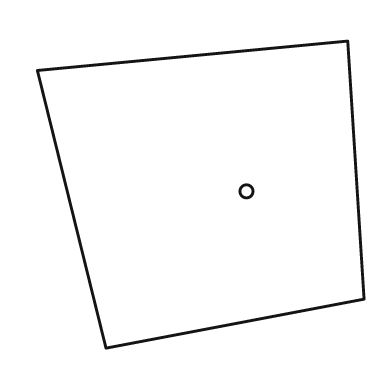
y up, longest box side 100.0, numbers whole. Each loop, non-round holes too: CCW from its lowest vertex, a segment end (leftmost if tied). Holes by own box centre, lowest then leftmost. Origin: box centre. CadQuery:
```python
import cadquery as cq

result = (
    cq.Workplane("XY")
    .moveTo(-29.0, -47.0)
    .lineTo(50.0, -32.0)
    .lineTo(45.0, 47.0)
    .lineTo(-50.0, 38.0)
    .close()
    .moveTo(14.0, 1.0)
    .circle(2.0)
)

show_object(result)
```